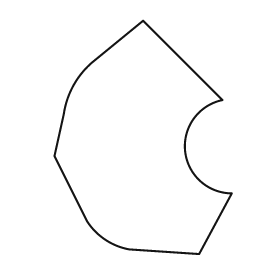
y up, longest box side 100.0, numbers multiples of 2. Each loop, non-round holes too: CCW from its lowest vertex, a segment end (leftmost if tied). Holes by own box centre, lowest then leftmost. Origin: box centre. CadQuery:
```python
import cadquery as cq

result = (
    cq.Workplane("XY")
    .moveTo(24.0, -50.0)
    .lineTo(38.0, -24.0)
    .threePointArc((18.0, -6.0), (34.0, 16.0))
    .lineTo(0.0, 50.0)
    .lineTo(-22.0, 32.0)
    .threePointArc((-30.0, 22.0), (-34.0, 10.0))
    .lineTo(-38.0, -8.0)
    .lineTo(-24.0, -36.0)
    .threePointArc((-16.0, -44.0), (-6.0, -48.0))
    .close()
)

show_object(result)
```